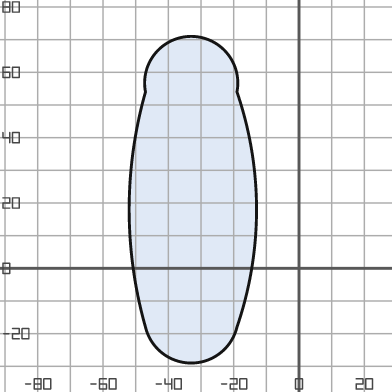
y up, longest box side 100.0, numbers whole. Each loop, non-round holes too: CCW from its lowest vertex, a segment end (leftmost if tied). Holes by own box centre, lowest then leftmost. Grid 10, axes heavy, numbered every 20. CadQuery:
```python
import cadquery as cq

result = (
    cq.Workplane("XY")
    .moveTo(-47.0, -18.0)
    .threePointArc((-33.0, -29.0), (-19.0, -18.0))
    .threePointArc((-13.0, 18.0), (-19.0, 54.0))
    .threePointArc((-33.0, 71.0), (-47.0, 54.0))
    .threePointArc((-52.0, 18.0), (-47.0, -18.0))
    .close()
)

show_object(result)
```